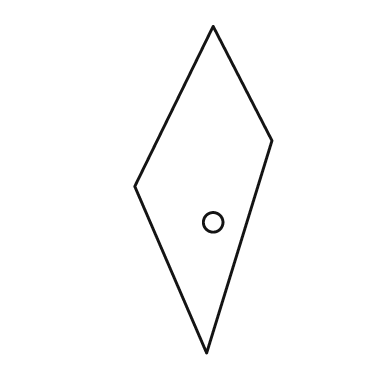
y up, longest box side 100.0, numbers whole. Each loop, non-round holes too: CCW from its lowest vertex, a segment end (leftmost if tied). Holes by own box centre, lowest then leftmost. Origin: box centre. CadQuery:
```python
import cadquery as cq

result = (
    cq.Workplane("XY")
    .moveTo(1.0, -50.0)
    .lineTo(21.0, 15.0)
    .lineTo(3.0, 50.0)
    .lineTo(-21.0, 1.0)
    .close()
    .moveTo(3.0, -10.0)
    .circle(3.0)
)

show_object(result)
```